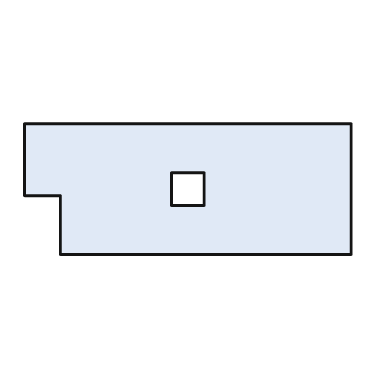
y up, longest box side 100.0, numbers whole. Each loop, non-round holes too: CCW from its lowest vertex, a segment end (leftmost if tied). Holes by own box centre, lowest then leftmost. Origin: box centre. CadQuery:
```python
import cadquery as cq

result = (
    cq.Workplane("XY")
    .moveTo(-39.0, -20.0)
    .lineTo(50.0, -20.0)
    .lineTo(50.0, 20.0)
    .lineTo(-50.0, 20.0)
    .lineTo(-50.0, -2.0)
    .lineTo(-39.0, -2.0)
    .close()
    .moveTo(-5.0, -5.0)
    .lineTo(5.0, -5.0)
    .lineTo(5.0, 5.0)
    .lineTo(-5.0, 5.0)
    .close()
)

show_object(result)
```